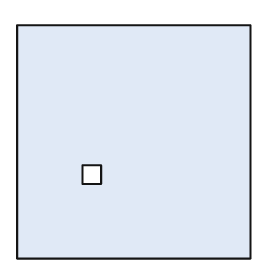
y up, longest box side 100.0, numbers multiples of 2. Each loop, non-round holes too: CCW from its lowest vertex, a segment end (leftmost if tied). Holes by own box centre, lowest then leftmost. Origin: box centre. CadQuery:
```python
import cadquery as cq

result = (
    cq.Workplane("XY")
    .moveTo(-50.0, -50.0)
    .lineTo(50.0, -50.0)
    .lineTo(50.0, 50.0)
    .lineTo(-50.0, 50.0)
    .close()
    .moveTo(-22.0, -18.0)
    .lineTo(-14.0, -18.0)
    .lineTo(-14.0, -10.0)
    .lineTo(-22.0, -10.0)
    .close()
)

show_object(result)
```